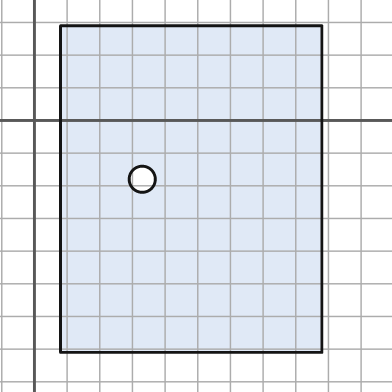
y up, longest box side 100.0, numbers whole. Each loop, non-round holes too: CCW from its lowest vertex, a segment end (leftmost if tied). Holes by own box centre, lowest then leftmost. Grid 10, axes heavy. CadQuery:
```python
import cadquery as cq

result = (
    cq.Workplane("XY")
    .moveTo(8.0, -71.0)
    .lineTo(88.0, -71.0)
    .lineTo(88.0, 29.0)
    .lineTo(8.0, 29.0)
    .close()
    .moveTo(33.0, -18.0)
    .circle(4.0)
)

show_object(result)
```